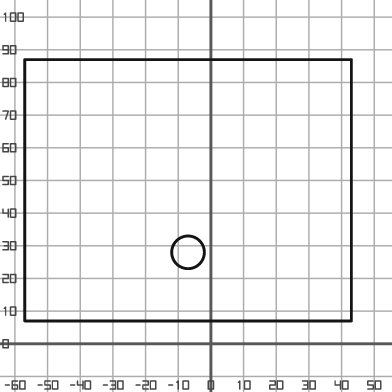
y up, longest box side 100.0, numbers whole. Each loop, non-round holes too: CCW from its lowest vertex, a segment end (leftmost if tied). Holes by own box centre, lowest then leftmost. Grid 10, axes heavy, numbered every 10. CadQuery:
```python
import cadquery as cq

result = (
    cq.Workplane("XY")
    .moveTo(-57.0, 7.0)
    .lineTo(43.0, 7.0)
    .lineTo(43.0, 87.0)
    .lineTo(-57.0, 87.0)
    .close()
    .moveTo(-7.0, 28.0)
    .circle(5.0)
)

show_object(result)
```